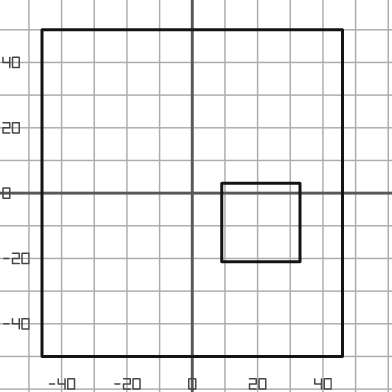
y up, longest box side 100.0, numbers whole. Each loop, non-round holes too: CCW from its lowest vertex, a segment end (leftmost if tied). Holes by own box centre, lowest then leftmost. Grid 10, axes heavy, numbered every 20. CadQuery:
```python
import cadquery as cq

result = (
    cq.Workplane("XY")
    .moveTo(-46.0, -50.0)
    .lineTo(46.0, -50.0)
    .lineTo(46.0, 50.0)
    .lineTo(-46.0, 50.0)
    .close()
    .moveTo(9.0, -21.0)
    .lineTo(33.0, -21.0)
    .lineTo(33.0, 3.0)
    .lineTo(9.0, 3.0)
    .close()
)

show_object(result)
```